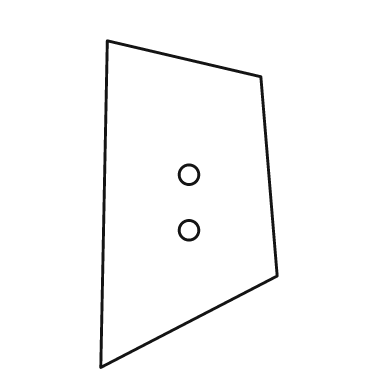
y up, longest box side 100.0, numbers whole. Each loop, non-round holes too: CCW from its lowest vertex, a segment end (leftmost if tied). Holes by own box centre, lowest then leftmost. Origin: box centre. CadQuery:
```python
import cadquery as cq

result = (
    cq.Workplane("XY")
    .moveTo(-27.0, -50.0)
    .lineTo(27.0, -22.0)
    .lineTo(22.0, 39.0)
    .lineTo(-25.0, 50.0)
    .close()
    .moveTo(0.0, -8.0)
    .circle(3.0)
    .moveTo(0.0, 9.0)
    .circle(3.0)
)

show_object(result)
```